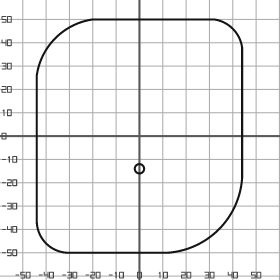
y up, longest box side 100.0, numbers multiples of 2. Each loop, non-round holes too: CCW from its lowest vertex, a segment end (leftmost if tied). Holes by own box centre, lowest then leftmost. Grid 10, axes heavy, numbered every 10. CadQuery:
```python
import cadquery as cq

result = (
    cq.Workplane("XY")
    .moveTo(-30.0, -50.0)
    .lineTo(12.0, -50.0)
    .threePointArc((34.0, -40.0), (44.0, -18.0))
    .lineTo(44.0, 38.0)
    .threePointArc((40.0, 46.0), (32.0, 50.0))
    .lineTo(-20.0, 50.0)
    .threePointArc((-36.0, 42.0), (-44.0, 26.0))
    .lineTo(-44.0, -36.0)
    .threePointArc((-40.0, -46.0), (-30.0, -50.0))
    .close()
    .moveTo(0.0, -14.0)
    .circle(2.0)
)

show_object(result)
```